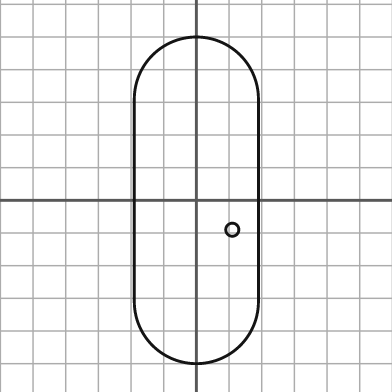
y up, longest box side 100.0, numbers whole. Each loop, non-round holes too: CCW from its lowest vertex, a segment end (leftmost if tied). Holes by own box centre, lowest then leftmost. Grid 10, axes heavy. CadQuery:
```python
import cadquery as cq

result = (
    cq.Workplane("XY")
    .moveTo(-19.0, -31.0)
    .threePointArc((0.0, -50.0), (19.0, -31.0))
    .lineTo(19.0, 31.0)
    .threePointArc((0.0, 50.0), (-19.0, 31.0))
    .close()
    .moveTo(11.0, -9.0)
    .circle(2.0)
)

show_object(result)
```